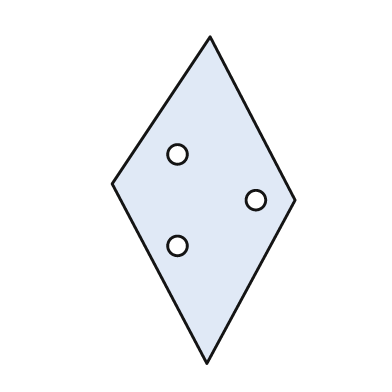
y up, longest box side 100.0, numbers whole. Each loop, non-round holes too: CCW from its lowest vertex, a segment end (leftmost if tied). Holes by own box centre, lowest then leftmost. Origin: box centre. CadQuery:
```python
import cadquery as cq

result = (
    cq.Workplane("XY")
    .moveTo(1.0, -50.0)
    .lineTo(28.0, 0.0)
    .lineTo(2.0, 50.0)
    .lineTo(-28.0, 5.0)
    .close()
    .moveTo(-8.0, -14.0)
    .circle(3.0)
    .moveTo(16.0, 0.0)
    .circle(3.0)
    .moveTo(-8.0, 14.0)
    .circle(3.0)
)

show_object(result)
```